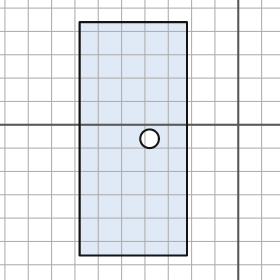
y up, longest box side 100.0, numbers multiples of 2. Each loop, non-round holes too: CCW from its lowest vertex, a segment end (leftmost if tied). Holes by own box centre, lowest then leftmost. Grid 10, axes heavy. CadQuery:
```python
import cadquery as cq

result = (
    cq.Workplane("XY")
    .moveTo(-68.0, -56.0)
    .lineTo(-22.0, -56.0)
    .lineTo(-22.0, 44.0)
    .lineTo(-68.0, 44.0)
    .close()
    .moveTo(-38.0, -6.0)
    .circle(4.0)
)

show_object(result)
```